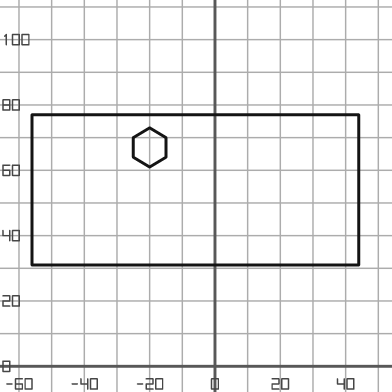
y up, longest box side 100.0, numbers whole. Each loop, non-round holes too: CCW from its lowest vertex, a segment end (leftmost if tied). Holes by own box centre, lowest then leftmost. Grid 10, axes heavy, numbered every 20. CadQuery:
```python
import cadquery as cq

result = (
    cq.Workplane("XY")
    .moveTo(-56.0, 31.0)
    .lineTo(44.0, 31.0)
    .lineTo(44.0, 77.0)
    .lineTo(-56.0, 77.0)
    .close()
    .moveTo(-20.0, 61.0)
    .lineTo(-15.0, 64.0)
    .lineTo(-15.0, 70.0)
    .lineTo(-20.0, 73.0)
    .lineTo(-25.0, 70.0)
    .lineTo(-25.0, 64.0)
    .close()
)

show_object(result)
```